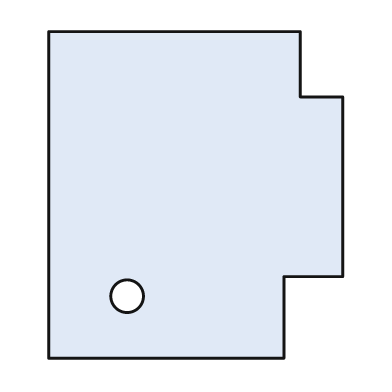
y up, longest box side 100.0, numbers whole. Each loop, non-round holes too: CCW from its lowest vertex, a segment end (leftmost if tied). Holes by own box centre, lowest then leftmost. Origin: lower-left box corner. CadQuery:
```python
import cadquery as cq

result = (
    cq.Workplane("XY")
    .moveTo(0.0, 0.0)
    .lineTo(72.0, 0.0)
    .lineTo(72.0, 25.0)
    .lineTo(90.0, 25.0)
    .lineTo(90.0, 80.0)
    .lineTo(77.0, 80.0)
    .lineTo(77.0, 100.0)
    .lineTo(0.0, 100.0)
    .close()
    .moveTo(24.0, 19.0)
    .circle(5.0)
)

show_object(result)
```